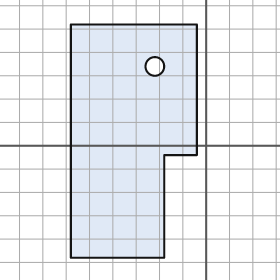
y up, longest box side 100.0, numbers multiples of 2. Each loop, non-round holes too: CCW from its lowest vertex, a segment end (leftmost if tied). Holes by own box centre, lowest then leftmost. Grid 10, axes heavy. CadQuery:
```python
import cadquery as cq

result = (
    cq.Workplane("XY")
    .moveTo(-58.0, -48.0)
    .lineTo(-18.0, -48.0)
    .lineTo(-18.0, -4.0)
    .lineTo(-4.0, -4.0)
    .lineTo(-4.0, 52.0)
    .lineTo(-58.0, 52.0)
    .close()
    .moveTo(-22.0, 34.0)
    .circle(4.0)
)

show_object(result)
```